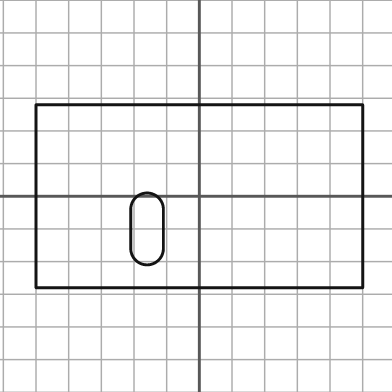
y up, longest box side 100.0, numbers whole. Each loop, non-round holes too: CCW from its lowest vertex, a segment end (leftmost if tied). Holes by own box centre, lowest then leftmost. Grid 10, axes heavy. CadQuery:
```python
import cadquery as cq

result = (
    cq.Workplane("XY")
    .moveTo(-50.0, -28.0)
    .lineTo(50.0, -28.0)
    .lineTo(50.0, 28.0)
    .lineTo(-50.0, 28.0)
    .close()
    .moveTo(-21.0, -16.0)
    .threePointArc((-16.0, -21.0), (-11.0, -16.0))
    .lineTo(-11.0, -4.0)
    .threePointArc((-16.0, 1.0), (-21.0, -4.0))
    .close()
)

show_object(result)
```